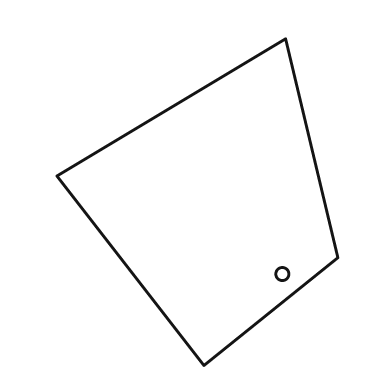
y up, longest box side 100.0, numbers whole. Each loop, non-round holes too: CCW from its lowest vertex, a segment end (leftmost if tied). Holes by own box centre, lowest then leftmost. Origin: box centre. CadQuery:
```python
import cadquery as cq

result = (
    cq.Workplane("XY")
    .moveTo(2.0, -50.0)
    .lineTo(43.0, -17.0)
    .lineTo(27.0, 50.0)
    .lineTo(-43.0, 8.0)
    .close()
    .moveTo(26.0, -22.0)
    .circle(2.0)
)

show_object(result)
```